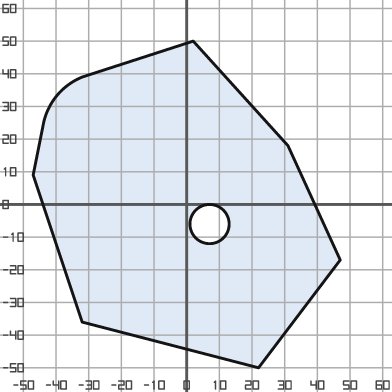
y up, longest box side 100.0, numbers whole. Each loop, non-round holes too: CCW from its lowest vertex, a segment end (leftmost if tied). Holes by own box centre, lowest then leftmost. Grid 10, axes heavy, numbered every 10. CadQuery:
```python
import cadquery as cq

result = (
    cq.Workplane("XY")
    .moveTo(22.0, -50.0)
    .lineTo(47.0, -17.0)
    .lineTo(31.0, 18.0)
    .lineTo(2.0, 50.0)
    .lineTo(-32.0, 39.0)
    .threePointArc((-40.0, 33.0), (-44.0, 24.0))
    .lineTo(-47.0, 9.0)
    .lineTo(-32.0, -36.0)
    .close()
    .moveTo(7.0, -6.0)
    .circle(6.0)
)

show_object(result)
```